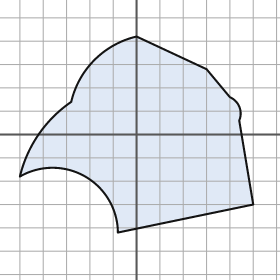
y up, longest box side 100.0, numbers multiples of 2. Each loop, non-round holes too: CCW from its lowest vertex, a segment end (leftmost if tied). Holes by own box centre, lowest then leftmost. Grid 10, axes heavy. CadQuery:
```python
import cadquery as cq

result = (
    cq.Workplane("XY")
    .moveTo(-8.0, -42.0)
    .lineTo(50.0, -30.0)
    .lineTo(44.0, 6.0)
    .threePointArc((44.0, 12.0), (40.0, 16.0))
    .lineTo(30.0, 28.0)
    .lineTo(0.0, 42.0)
    .threePointArc((-18.0, 32.0), (-28.0, 14.0))
    .threePointArc((-42.0, 0.0), (-50.0, -18.0))
    .threePointArc((-22.0, -18.0), (-8.0, -42.0))
    .close()
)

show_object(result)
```